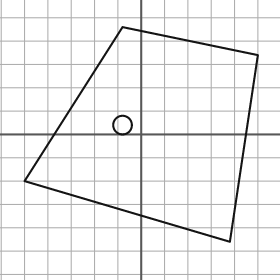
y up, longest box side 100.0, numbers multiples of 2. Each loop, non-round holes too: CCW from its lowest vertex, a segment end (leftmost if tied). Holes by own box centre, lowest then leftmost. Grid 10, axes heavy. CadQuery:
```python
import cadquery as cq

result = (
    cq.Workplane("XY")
    .moveTo(38.0, -46.0)
    .lineTo(50.0, 34.0)
    .lineTo(-8.0, 46.0)
    .lineTo(-50.0, -20.0)
    .close()
    .moveTo(-8.0, 4.0)
    .circle(4.0)
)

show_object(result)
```